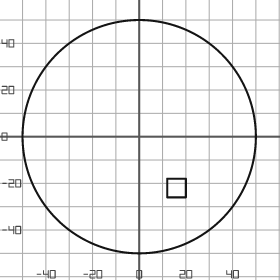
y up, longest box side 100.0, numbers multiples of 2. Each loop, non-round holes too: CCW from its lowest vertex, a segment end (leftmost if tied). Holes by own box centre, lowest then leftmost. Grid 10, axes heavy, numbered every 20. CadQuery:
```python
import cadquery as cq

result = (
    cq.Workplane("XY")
    .moveTo(0.0, 0.0)
    .circle(50.0)
    .moveTo(12.0, -26.0)
    .lineTo(20.0, -26.0)
    .lineTo(20.0, -18.0)
    .lineTo(12.0, -18.0)
    .close()
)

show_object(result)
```